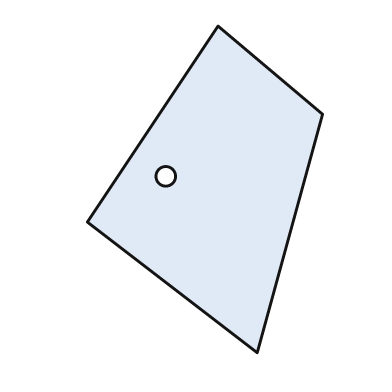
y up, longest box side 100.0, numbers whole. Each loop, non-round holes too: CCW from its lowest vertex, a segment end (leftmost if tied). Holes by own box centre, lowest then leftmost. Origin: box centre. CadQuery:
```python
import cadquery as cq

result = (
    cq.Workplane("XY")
    .moveTo(16.0, -50.0)
    .lineTo(36.0, 23.0)
    .lineTo(4.0, 50.0)
    .lineTo(-36.0, -10.0)
    .close()
    .moveTo(-12.0, 4.0)
    .circle(3.0)
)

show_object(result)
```